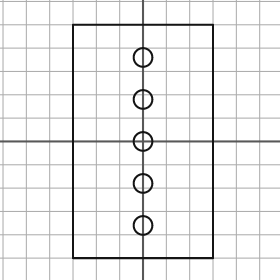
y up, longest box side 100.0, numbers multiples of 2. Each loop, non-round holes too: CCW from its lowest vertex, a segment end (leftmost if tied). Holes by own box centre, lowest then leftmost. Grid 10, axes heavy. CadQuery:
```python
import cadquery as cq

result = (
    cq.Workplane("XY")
    .moveTo(-30.0, -50.0)
    .lineTo(30.0, -50.0)
    .lineTo(30.0, 50.0)
    .lineTo(-30.0, 50.0)
    .close()
    .moveTo(0.0, -36.0)
    .circle(4.0)
    .moveTo(0.0, -18.0)
    .circle(4.0)
    .moveTo(0.0, 0.0)
    .circle(4.0)
    .moveTo(0.0, 18.0)
    .circle(4.0)
    .moveTo(0.0, 36.0)
    .circle(4.0)
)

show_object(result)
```